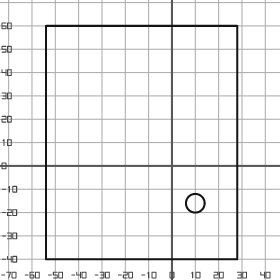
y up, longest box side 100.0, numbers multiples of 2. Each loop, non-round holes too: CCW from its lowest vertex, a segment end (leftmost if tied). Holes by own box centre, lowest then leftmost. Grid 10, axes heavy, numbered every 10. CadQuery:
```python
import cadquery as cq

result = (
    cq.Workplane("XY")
    .moveTo(-54.0, -40.0)
    .lineTo(28.0, -40.0)
    .lineTo(28.0, 60.0)
    .lineTo(-54.0, 60.0)
    .close()
    .moveTo(10.0, -16.0)
    .circle(4.0)
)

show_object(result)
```